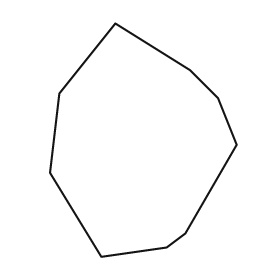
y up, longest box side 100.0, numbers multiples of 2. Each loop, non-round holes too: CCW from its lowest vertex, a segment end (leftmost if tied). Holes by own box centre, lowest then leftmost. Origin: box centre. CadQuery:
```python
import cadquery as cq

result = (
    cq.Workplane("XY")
    .moveTo(-18.0, -50.0)
    .lineTo(10.0, -46.0)
    .lineTo(18.0, -40.0)
    .lineTo(40.0, -2.0)
    .lineTo(32.0, 18.0)
    .lineTo(20.0, 30.0)
    .lineTo(-12.0, 50.0)
    .lineTo(-36.0, 20.0)
    .lineTo(-40.0, -14.0)
    .close()
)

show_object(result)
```